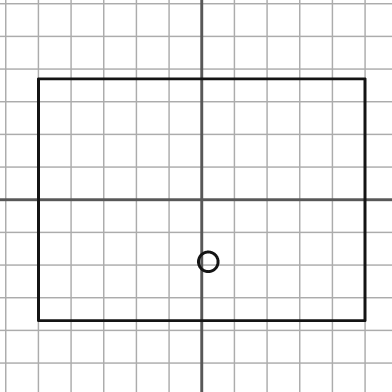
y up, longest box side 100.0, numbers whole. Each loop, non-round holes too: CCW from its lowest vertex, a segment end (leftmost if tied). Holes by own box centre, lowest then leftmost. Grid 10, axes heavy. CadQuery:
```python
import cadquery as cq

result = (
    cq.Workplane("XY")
    .moveTo(-50.0, -37.0)
    .lineTo(50.0, -37.0)
    .lineTo(50.0, 37.0)
    .lineTo(-50.0, 37.0)
    .close()
    .moveTo(2.0, -19.0)
    .circle(3.0)
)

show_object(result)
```